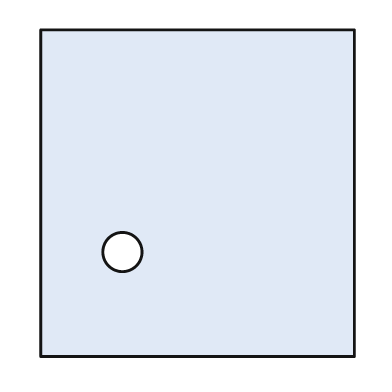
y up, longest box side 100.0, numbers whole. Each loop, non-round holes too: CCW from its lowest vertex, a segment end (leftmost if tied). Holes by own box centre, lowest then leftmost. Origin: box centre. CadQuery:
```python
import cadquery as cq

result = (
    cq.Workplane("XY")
    .moveTo(-48.0, -50.0)
    .lineTo(48.0, -50.0)
    .lineTo(48.0, 50.0)
    .lineTo(-48.0, 50.0)
    .close()
    .moveTo(-23.0, -18.0)
    .circle(6.0)
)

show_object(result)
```